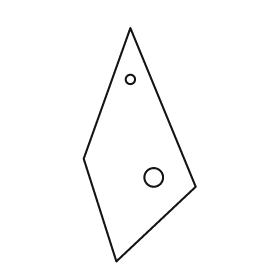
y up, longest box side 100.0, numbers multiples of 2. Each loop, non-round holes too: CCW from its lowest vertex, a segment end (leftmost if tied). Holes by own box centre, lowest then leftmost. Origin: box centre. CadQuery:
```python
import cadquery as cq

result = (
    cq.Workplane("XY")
    .moveTo(-10.0, -50.0)
    .lineTo(24.0, -18.0)
    .lineTo(-4.0, 50.0)
    .lineTo(-24.0, -6.0)
    .close()
    .moveTo(6.0, -14.0)
    .circle(4.0)
    .moveTo(-4.0, 28.0)
    .circle(2.0)
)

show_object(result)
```